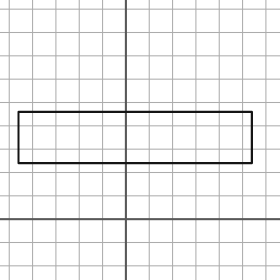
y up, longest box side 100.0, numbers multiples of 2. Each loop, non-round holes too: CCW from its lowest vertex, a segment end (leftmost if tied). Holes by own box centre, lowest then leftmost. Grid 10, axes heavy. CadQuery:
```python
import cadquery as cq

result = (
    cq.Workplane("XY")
    .moveTo(-46.0, 24.0)
    .lineTo(54.0, 24.0)
    .lineTo(54.0, 46.0)
    .lineTo(-46.0, 46.0)
    .close()
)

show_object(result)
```